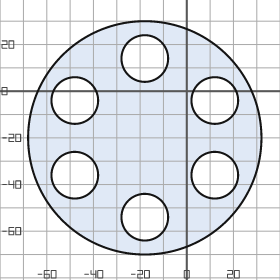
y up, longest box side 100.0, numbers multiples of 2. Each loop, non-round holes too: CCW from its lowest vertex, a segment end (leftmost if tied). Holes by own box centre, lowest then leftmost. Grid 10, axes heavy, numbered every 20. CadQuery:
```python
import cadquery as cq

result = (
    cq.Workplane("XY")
    .moveTo(-18.0, -20.0)
    .circle(50.0)
    .moveTo(-18.0, -54.0)
    .circle(10.0)
    .moveTo(-48.0, -36.0)
    .circle(10.0)
    .moveTo(12.0, -36.0)
    .circle(10.0)
    .moveTo(-48.0, -4.0)
    .circle(10.0)
    .moveTo(12.0, -4.0)
    .circle(10.0)
    .moveTo(-18.0, 14.0)
    .circle(10.0)
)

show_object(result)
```